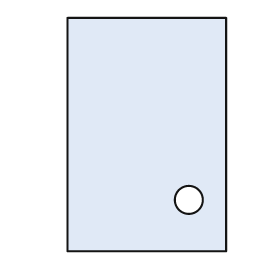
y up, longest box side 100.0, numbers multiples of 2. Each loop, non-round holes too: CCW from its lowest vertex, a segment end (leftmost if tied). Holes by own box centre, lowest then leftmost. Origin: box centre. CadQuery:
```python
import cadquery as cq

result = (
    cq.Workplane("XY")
    .moveTo(-34.0, -50.0)
    .lineTo(34.0, -50.0)
    .lineTo(34.0, 50.0)
    .lineTo(-34.0, 50.0)
    .close()
    .moveTo(18.0, -28.0)
    .circle(6.0)
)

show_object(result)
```